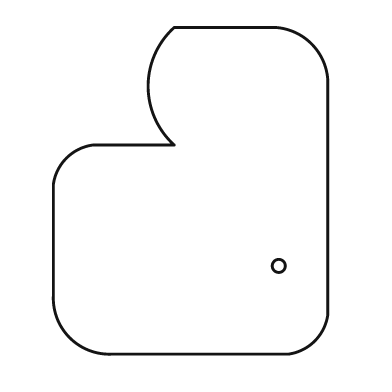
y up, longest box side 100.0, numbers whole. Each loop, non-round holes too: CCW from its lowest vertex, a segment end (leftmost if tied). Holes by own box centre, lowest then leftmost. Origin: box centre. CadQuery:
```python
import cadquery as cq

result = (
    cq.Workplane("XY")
    .moveTo(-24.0, -50.0)
    .lineTo(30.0, -50.0)
    .threePointArc((38.0, -46.0), (42.0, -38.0))
    .lineTo(42.0, 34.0)
    .threePointArc((37.0, 45.0), (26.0, 50.0))
    .lineTo(-5.0, 50.0)
    .threePointArc((-13.0, 32.0), (-5.0, 14.0))
    .lineTo(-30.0, 14.0)
    .threePointArc((-38.0, 10.0), (-42.0, 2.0))
    .lineTo(-42.0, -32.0)
    .threePointArc((-37.0, -45.0), (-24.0, -50.0))
    .close()
    .moveTo(27.0, -23.0)
    .circle(2.0)
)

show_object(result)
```